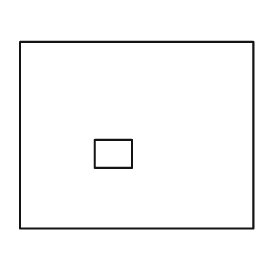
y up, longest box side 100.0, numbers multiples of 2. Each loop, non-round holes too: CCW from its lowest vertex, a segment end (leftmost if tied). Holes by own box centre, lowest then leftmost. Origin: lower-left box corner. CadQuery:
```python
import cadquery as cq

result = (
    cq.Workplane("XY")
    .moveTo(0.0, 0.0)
    .lineTo(100.0, 0.0)
    .lineTo(100.0, 80.0)
    .lineTo(0.0, 80.0)
    .close()
    .moveTo(32.0, 26.0)
    .lineTo(48.0, 26.0)
    .lineTo(48.0, 38.0)
    .lineTo(32.0, 38.0)
    .close()
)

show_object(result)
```